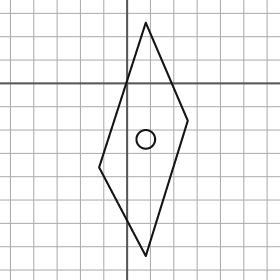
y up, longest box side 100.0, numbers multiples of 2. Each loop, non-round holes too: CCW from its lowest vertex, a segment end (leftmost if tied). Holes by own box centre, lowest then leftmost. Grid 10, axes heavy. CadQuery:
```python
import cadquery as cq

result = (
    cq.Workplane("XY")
    .moveTo(8.0, -74.0)
    .lineTo(26.0, -16.0)
    .lineTo(8.0, 26.0)
    .lineTo(-12.0, -36.0)
    .close()
    .moveTo(8.0, -24.0)
    .circle(4.0)
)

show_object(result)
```